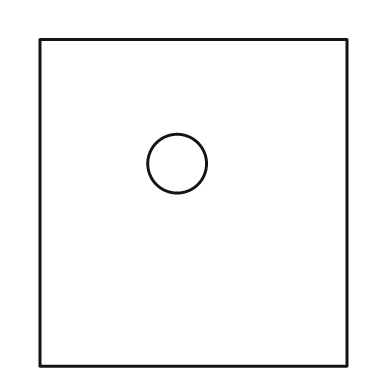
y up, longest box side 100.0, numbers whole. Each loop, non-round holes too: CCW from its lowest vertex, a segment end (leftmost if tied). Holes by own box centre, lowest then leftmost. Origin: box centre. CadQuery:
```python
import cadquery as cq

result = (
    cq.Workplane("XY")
    .moveTo(-47.0, -50.0)
    .lineTo(47.0, -50.0)
    .lineTo(47.0, 50.0)
    .lineTo(-47.0, 50.0)
    .close()
    .moveTo(-5.0, 12.0)
    .circle(9.0)
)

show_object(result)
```